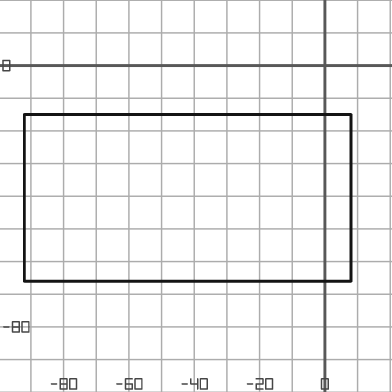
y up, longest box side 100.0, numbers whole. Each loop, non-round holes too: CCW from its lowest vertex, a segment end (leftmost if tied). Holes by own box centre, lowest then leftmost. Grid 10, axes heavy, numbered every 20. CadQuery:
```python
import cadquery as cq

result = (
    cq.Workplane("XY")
    .moveTo(-92.0, -66.0)
    .lineTo(8.0, -66.0)
    .lineTo(8.0, -15.0)
    .lineTo(-92.0, -15.0)
    .close()
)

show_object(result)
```